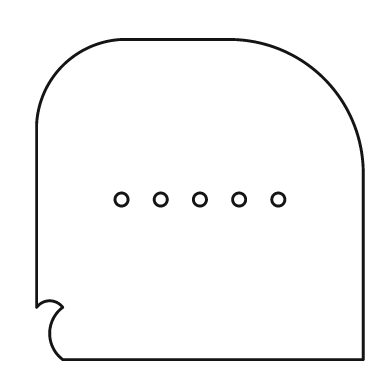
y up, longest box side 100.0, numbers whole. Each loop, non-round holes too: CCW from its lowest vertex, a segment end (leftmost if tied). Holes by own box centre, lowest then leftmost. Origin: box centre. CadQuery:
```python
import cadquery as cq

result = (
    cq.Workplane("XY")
    .moveTo(-42.0, -49.0)
    .lineTo(50.0, -49.0)
    .lineTo(50.0, 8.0)
    .threePointArc((38.0, 37.0), (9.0, 49.0))
    .lineTo(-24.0, 49.0)
    .threePointArc((-42.0, 41.0), (-50.0, 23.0))
    .lineTo(-50.0, -33.0)
    .threePointArc((-46.0, -31.0), (-42.0, -33.0))
    .threePointArc((-46.0, -41.0), (-42.0, -49.0))
    .close()
    .moveTo(-24.0, 0.0)
    .circle(2.0)
    .moveTo(-12.0, 0.0)
    .circle(2.0)
    .moveTo(0.0, 0.0)
    .circle(2.0)
    .moveTo(12.0, 0.0)
    .circle(2.0)
    .moveTo(24.0, 0.0)
    .circle(2.0)
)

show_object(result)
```